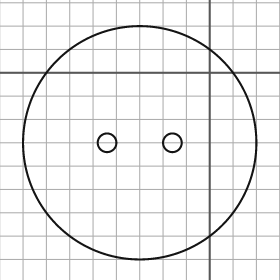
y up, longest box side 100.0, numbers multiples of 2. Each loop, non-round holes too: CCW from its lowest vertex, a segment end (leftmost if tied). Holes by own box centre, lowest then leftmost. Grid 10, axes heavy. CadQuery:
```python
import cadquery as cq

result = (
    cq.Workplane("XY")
    .moveTo(-30.0, -30.0)
    .circle(50.0)
    .moveTo(-44.0, -30.0)
    .circle(4.0)
    .moveTo(-16.0, -30.0)
    .circle(4.0)
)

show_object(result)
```